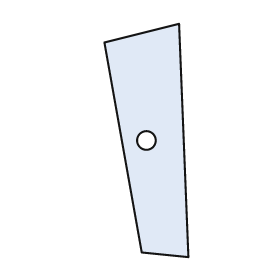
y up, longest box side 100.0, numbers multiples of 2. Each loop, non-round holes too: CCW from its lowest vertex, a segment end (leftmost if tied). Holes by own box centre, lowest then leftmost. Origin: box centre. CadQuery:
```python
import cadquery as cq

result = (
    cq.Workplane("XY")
    .moveTo(18.0, -50.0)
    .lineTo(14.0, 50.0)
    .lineTo(-18.0, 42.0)
    .lineTo(-2.0, -48.0)
    .close()
    .moveTo(0.0, 0.0)
    .circle(4.0)
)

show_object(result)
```